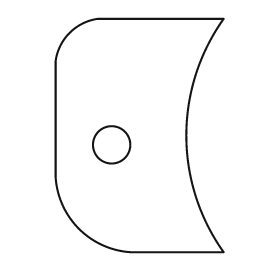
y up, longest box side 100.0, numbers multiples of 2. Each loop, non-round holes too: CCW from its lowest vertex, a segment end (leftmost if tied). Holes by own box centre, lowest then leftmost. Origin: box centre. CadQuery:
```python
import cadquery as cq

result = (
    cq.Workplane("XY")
    .moveTo(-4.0, -50.0)
    .lineTo(36.0, -50.0)
    .threePointArc((20.0, 0.0), (36.0, 50.0))
    .lineTo(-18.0, 50.0)
    .threePointArc((-30.0, 44.0), (-36.0, 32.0))
    .lineTo(-36.0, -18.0)
    .threePointArc((-26.0, -40.0), (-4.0, -50.0))
    .close()
    .moveTo(-12.0, -4.0)
    .circle(8.0)
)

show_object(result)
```